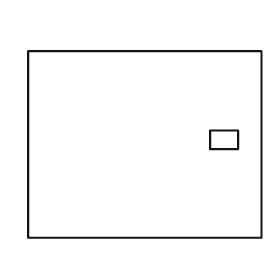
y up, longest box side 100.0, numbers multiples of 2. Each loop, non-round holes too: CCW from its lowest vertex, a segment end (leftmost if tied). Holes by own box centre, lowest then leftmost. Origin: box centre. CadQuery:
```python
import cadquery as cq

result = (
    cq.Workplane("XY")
    .moveTo(-50.0, -40.0)
    .lineTo(50.0, -40.0)
    .lineTo(50.0, 40.0)
    .lineTo(-50.0, 40.0)
    .close()
    .moveTo(28.0, -2.0)
    .lineTo(40.0, -2.0)
    .lineTo(40.0, 6.0)
    .lineTo(28.0, 6.0)
    .close()
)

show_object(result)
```